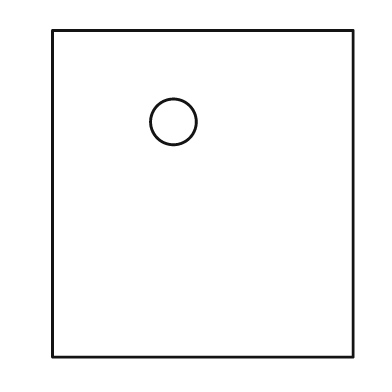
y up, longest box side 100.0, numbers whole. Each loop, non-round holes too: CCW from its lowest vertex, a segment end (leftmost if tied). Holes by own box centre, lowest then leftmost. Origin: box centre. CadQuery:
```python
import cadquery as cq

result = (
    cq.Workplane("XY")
    .moveTo(-46.0, -50.0)
    .lineTo(46.0, -50.0)
    .lineTo(46.0, 50.0)
    .lineTo(-46.0, 50.0)
    .close()
    .moveTo(-9.0, 22.0)
    .circle(7.0)
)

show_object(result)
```